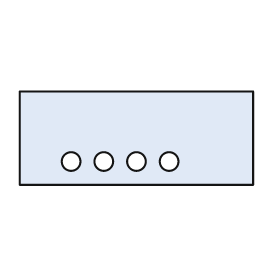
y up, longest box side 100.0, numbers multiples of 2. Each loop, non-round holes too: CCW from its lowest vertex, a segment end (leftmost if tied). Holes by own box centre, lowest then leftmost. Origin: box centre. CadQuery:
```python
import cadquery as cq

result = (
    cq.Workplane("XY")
    .moveTo(-50.0, -20.0)
    .lineTo(50.0, -20.0)
    .lineTo(50.0, 20.0)
    .lineTo(-50.0, 20.0)
    .close()
    .moveTo(-28.0, -10.0)
    .circle(4.0)
    .moveTo(-14.0, -10.0)
    .circle(4.0)
    .moveTo(0.0, -10.0)
    .circle(4.0)
    .moveTo(14.0, -10.0)
    .circle(4.0)
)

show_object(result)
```